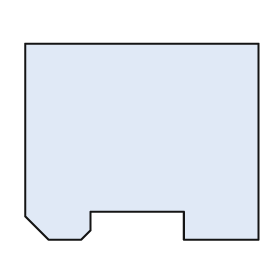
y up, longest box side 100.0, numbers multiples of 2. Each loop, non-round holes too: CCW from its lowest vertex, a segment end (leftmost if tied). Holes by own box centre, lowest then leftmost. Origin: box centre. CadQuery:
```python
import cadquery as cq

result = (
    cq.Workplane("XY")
    .moveTo(-40.0, -42.0)
    .lineTo(-26.0, -42.0)
    .lineTo(-22.0, -38.0)
    .lineTo(-22.0, -30.0)
    .lineTo(18.0, -30.0)
    .lineTo(18.0, -42.0)
    .lineTo(50.0, -42.0)
    .lineTo(50.0, 42.0)
    .lineTo(-50.0, 42.0)
    .lineTo(-50.0, -32.0)
    .close()
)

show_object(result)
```